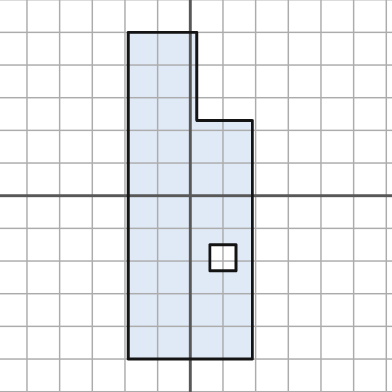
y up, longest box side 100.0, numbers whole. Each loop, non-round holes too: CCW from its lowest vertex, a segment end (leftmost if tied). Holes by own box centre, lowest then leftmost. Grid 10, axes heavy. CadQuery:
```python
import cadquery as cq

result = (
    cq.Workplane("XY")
    .moveTo(-19.0, -50.0)
    .lineTo(19.0, -50.0)
    .lineTo(19.0, 23.0)
    .lineTo(2.0, 23.0)
    .lineTo(2.0, 50.0)
    .lineTo(-19.0, 50.0)
    .close()
    .moveTo(6.0, -23.0)
    .lineTo(14.0, -23.0)
    .lineTo(14.0, -15.0)
    .lineTo(6.0, -15.0)
    .close()
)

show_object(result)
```